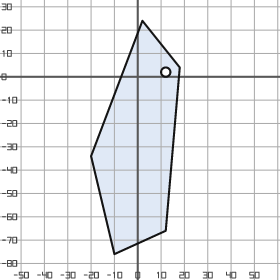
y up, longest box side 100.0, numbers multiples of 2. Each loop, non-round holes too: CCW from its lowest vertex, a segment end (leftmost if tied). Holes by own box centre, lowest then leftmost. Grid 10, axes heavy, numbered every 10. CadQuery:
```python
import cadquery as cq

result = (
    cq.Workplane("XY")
    .moveTo(-10.0, -76.0)
    .lineTo(12.0, -66.0)
    .lineTo(18.0, 4.0)
    .lineTo(2.0, 24.0)
    .lineTo(-20.0, -34.0)
    .close()
    .moveTo(12.0, 2.0)
    .circle(2.0)
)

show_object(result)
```